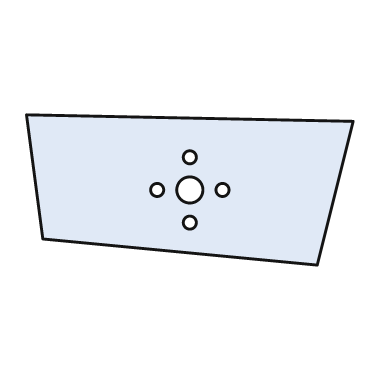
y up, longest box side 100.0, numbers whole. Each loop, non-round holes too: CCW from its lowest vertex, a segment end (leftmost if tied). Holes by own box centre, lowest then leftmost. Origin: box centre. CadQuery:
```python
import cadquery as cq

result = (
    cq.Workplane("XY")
    .moveTo(39.0, -23.0)
    .lineTo(50.0, 21.0)
    .lineTo(-50.0, 23.0)
    .lineTo(-45.0, -15.0)
    .close()
    .moveTo(0.0, -10.0)
    .circle(2.0)
    .moveTo(-10.0, 0.0)
    .circle(2.0)
    .moveTo(0.0, 0.0)
    .circle(4.0)
    .moveTo(10.0, 0.0)
    .circle(2.0)
    .moveTo(0.0, 10.0)
    .circle(2.0)
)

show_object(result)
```